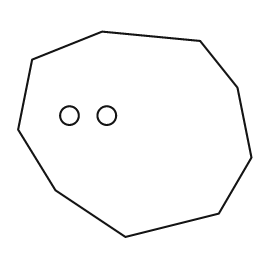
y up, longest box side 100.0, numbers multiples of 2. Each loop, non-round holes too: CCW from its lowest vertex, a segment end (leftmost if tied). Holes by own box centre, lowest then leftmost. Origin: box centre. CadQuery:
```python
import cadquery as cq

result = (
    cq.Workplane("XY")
    .moveTo(-4.0, -44.0)
    .lineTo(36.0, -34.0)
    .lineTo(50.0, -10.0)
    .lineTo(44.0, 20.0)
    .lineTo(28.0, 40.0)
    .lineTo(-14.0, 44.0)
    .lineTo(-44.0, 32.0)
    .lineTo(-50.0, 2.0)
    .lineTo(-34.0, -24.0)
    .close()
    .moveTo(-28.0, 8.0)
    .circle(4.0)
    .moveTo(-12.0, 8.0)
    .circle(4.0)
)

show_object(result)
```